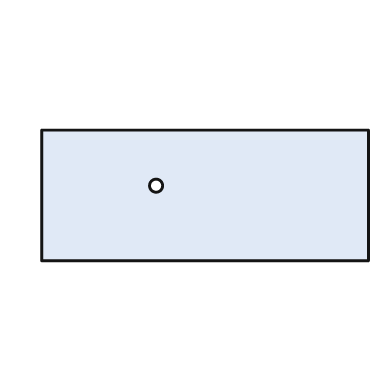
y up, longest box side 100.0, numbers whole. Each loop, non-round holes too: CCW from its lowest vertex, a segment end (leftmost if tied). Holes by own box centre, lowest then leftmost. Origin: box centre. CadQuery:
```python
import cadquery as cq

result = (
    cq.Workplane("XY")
    .moveTo(-50.0, -20.0)
    .lineTo(50.0, -20.0)
    .lineTo(50.0, 20.0)
    .lineTo(-50.0, 20.0)
    .close()
    .moveTo(-15.0, 3.0)
    .circle(2.0)
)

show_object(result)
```